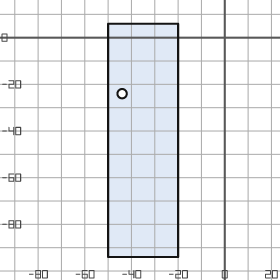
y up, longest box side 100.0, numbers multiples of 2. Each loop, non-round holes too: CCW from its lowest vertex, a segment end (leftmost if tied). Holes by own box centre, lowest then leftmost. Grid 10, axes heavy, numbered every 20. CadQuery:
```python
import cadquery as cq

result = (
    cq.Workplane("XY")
    .moveTo(-50.0, -94.0)
    .lineTo(-20.0, -94.0)
    .lineTo(-20.0, 6.0)
    .lineTo(-50.0, 6.0)
    .close()
    .moveTo(-44.0, -24.0)
    .circle(2.0)
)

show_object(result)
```